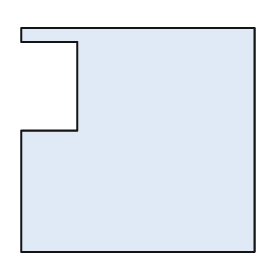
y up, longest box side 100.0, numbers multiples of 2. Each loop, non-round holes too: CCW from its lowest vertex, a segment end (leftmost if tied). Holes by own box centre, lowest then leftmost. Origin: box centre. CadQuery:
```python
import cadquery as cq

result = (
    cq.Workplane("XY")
    .moveTo(-50.0, -48.0)
    .lineTo(50.0, -48.0)
    .lineTo(50.0, 48.0)
    .lineTo(-50.0, 48.0)
    .lineTo(-50.0, 42.0)
    .lineTo(-26.0, 42.0)
    .lineTo(-26.0, 4.0)
    .lineTo(-50.0, 4.0)
    .close()
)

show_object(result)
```